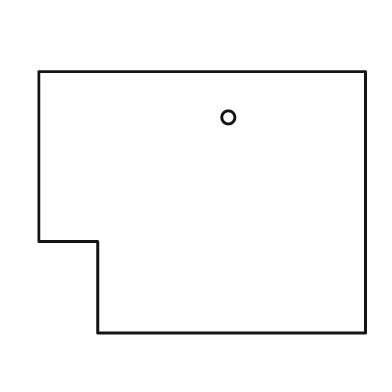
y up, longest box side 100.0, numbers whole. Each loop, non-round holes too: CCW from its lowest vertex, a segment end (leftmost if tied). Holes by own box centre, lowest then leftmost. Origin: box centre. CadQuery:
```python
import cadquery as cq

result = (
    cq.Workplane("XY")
    .moveTo(-32.0, -40.0)
    .lineTo(50.0, -40.0)
    .lineTo(50.0, 40.0)
    .lineTo(-50.0, 40.0)
    .lineTo(-50.0, -12.0)
    .lineTo(-32.0, -12.0)
    .close()
    .moveTo(8.0, 26.0)
    .circle(2.0)
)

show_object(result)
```